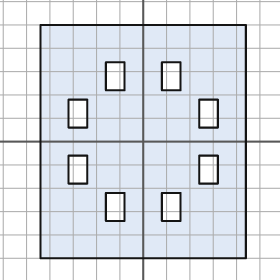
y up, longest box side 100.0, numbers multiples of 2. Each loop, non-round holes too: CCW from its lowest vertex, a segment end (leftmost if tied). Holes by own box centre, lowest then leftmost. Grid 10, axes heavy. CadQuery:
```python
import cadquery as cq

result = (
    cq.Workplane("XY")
    .moveTo(-44.0, -50.0)
    .lineTo(44.0, -50.0)
    .lineTo(44.0, 50.0)
    .lineTo(-44.0, 50.0)
    .close()
    .moveTo(-16.0, -34.0)
    .lineTo(-8.0, -34.0)
    .lineTo(-8.0, -22.0)
    .lineTo(-16.0, -22.0)
    .close()
    .moveTo(8.0, -34.0)
    .lineTo(16.0, -34.0)
    .lineTo(16.0, -22.0)
    .lineTo(8.0, -22.0)
    .close()
    .moveTo(-32.0, -18.0)
    .lineTo(-24.0, -18.0)
    .lineTo(-24.0, -6.0)
    .lineTo(-32.0, -6.0)
    .close()
    .moveTo(24.0, -18.0)
    .lineTo(32.0, -18.0)
    .lineTo(32.0, -6.0)
    .lineTo(24.0, -6.0)
    .close()
    .moveTo(-32.0, 6.0)
    .lineTo(-24.0, 6.0)
    .lineTo(-24.0, 18.0)
    .lineTo(-32.0, 18.0)
    .close()
    .moveTo(24.0, 6.0)
    .lineTo(32.0, 6.0)
    .lineTo(32.0, 18.0)
    .lineTo(24.0, 18.0)
    .close()
    .moveTo(-16.0, 22.0)
    .lineTo(-8.0, 22.0)
    .lineTo(-8.0, 34.0)
    .lineTo(-16.0, 34.0)
    .close()
    .moveTo(8.0, 22.0)
    .lineTo(16.0, 22.0)
    .lineTo(16.0, 34.0)
    .lineTo(8.0, 34.0)
    .close()
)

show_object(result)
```